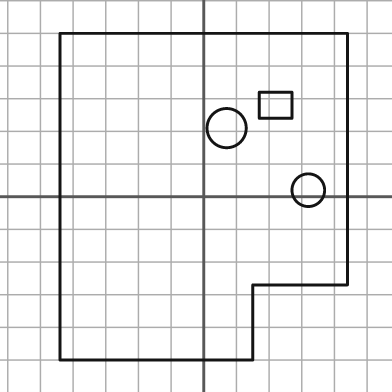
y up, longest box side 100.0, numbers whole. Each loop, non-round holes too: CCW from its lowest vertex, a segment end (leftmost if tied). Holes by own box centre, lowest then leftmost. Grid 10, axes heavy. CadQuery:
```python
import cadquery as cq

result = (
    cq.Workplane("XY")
    .moveTo(-44.0, -50.0)
    .lineTo(15.0, -50.0)
    .lineTo(15.0, -27.0)
    .lineTo(44.0, -27.0)
    .lineTo(44.0, 50.0)
    .lineTo(-44.0, 50.0)
    .close()
    .moveTo(32.0, 2.0)
    .circle(5.0)
    .moveTo(7.0, 21.0)
    .circle(6.0)
    .moveTo(17.0, 24.0)
    .lineTo(27.0, 24.0)
    .lineTo(27.0, 32.0)
    .lineTo(17.0, 32.0)
    .close()
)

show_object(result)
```